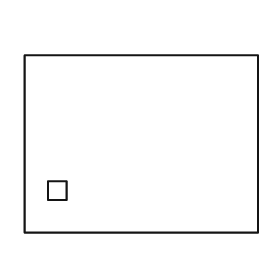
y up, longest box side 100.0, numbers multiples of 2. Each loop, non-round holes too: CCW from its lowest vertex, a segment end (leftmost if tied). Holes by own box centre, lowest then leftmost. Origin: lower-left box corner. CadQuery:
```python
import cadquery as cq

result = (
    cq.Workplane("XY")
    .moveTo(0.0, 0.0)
    .lineTo(100.0, 0.0)
    .lineTo(100.0, 76.0)
    .lineTo(0.0, 76.0)
    .close()
    .moveTo(10.0, 14.0)
    .lineTo(18.0, 14.0)
    .lineTo(18.0, 22.0)
    .lineTo(10.0, 22.0)
    .close()
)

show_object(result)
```